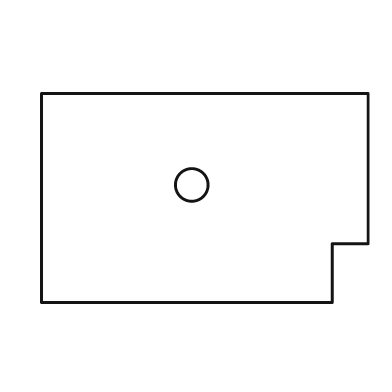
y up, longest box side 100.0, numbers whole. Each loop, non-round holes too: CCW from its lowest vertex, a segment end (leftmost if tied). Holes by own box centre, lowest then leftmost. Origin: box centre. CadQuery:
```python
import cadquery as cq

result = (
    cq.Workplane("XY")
    .moveTo(-50.0, -32.0)
    .lineTo(39.0, -32.0)
    .lineTo(39.0, -14.0)
    .lineTo(50.0, -14.0)
    .lineTo(50.0, 32.0)
    .lineTo(-50.0, 32.0)
    .close()
    .moveTo(-4.0, 4.0)
    .circle(5.0)
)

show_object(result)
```